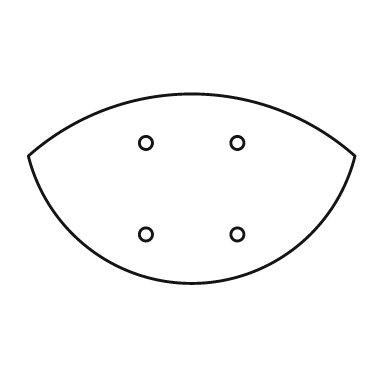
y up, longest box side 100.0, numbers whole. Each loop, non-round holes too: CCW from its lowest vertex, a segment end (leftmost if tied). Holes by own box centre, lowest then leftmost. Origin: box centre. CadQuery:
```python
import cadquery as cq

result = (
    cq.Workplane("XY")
    .moveTo(-50.0, 10.0)
    .threePointArc((0.0, -29.0), (50.0, 10.0))
    .threePointArc((0.0, 29.0), (-50.0, 10.0))
    .close()
    .moveTo(-14.0, -14.0)
    .circle(2.0)
    .moveTo(14.0, -14.0)
    .circle(2.0)
    .moveTo(-14.0, 14.0)
    .circle(2.0)
    .moveTo(14.0, 14.0)
    .circle(2.0)
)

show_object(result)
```